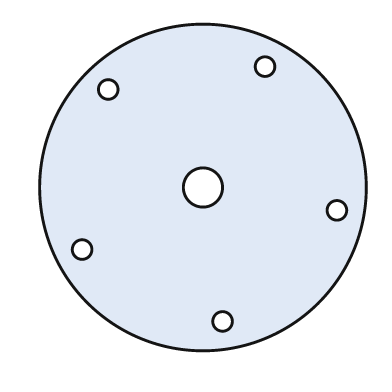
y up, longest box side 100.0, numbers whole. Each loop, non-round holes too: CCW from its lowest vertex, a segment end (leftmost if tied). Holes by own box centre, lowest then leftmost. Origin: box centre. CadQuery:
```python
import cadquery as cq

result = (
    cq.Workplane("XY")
    .moveTo(0.0, 0.0)
    .circle(50.0)
    .moveTo(6.0, -41.0)
    .circle(3.0)
    .moveTo(-37.0, -19.0)
    .circle(3.0)
    .moveTo(41.0, -7.0)
    .circle(3.0)
    .moveTo(0.0, 0.0)
    .circle(6.0)
    .moveTo(-29.0, 30.0)
    .circle(3.0)
    .moveTo(19.0, 37.0)
    .circle(3.0)
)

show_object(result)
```